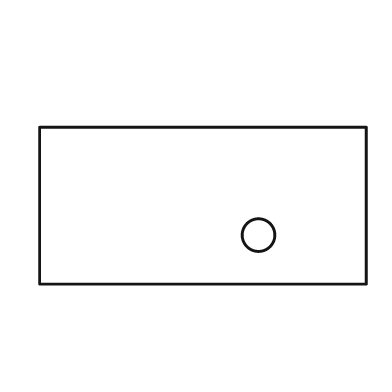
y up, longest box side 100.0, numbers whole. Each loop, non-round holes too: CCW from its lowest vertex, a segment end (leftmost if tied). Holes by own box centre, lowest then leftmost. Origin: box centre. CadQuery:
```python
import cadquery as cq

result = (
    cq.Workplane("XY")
    .moveTo(-50.0, -24.0)
    .lineTo(50.0, -24.0)
    .lineTo(50.0, 24.0)
    .lineTo(-50.0, 24.0)
    .close()
    .moveTo(17.0, -9.0)
    .circle(5.0)
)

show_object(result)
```